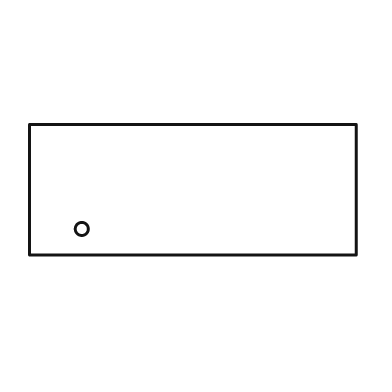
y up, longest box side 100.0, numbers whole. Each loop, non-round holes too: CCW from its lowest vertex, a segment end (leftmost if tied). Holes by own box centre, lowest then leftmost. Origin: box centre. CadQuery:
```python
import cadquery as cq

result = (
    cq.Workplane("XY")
    .moveTo(-50.0, -20.0)
    .lineTo(50.0, -20.0)
    .lineTo(50.0, 20.0)
    .lineTo(-50.0, 20.0)
    .close()
    .moveTo(-34.0, -12.0)
    .circle(2.0)
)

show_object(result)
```